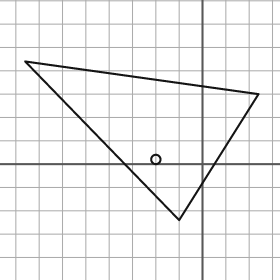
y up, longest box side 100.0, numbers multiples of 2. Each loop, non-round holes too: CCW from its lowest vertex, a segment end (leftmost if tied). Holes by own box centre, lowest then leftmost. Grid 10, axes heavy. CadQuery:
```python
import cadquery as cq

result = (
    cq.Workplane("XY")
    .moveTo(-10.0, -24.0)
    .lineTo(24.0, 30.0)
    .lineTo(-76.0, 44.0)
    .close()
    .moveTo(-20.0, 2.0)
    .circle(2.0)
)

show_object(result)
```